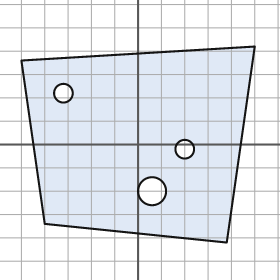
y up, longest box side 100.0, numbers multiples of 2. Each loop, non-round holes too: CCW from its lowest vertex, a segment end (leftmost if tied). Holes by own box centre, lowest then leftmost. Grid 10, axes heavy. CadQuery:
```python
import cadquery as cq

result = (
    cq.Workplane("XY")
    .moveTo(38.0, -42.0)
    .lineTo(50.0, 42.0)
    .lineTo(-50.0, 36.0)
    .lineTo(-40.0, -34.0)
    .close()
    .moveTo(6.0, -20.0)
    .circle(6.0)
    .moveTo(20.0, -2.0)
    .circle(4.0)
    .moveTo(-32.0, 22.0)
    .circle(4.0)
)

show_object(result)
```